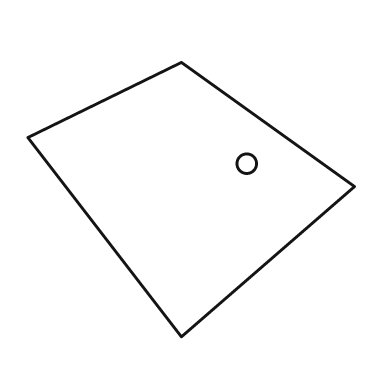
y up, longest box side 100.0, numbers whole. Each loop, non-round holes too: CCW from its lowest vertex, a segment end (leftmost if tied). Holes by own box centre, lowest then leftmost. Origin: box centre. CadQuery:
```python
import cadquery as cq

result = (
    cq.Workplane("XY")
    .moveTo(-3.0, -42.0)
    .lineTo(50.0, 4.0)
    .lineTo(-3.0, 42.0)
    .lineTo(-50.0, 19.0)
    .close()
    .moveTo(17.0, 11.0)
    .circle(3.0)
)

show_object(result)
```